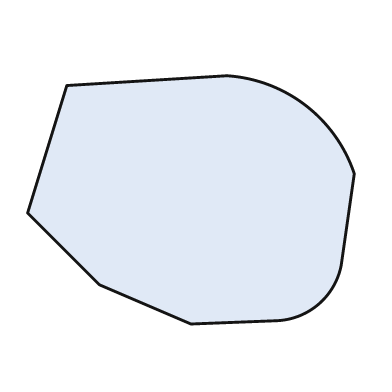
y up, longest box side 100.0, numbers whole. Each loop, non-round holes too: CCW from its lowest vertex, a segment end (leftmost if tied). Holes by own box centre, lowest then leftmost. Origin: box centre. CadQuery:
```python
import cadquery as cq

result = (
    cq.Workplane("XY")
    .moveTo(0.0, -38.0)
    .lineTo(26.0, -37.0)
    .threePointArc((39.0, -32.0), (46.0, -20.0))
    .lineTo(50.0, 8.0)
    .threePointArc((35.0, 29.0), (11.0, 38.0))
    .lineTo(-38.0, 35.0)
    .lineTo(-50.0, -4.0)
    .lineTo(-28.0, -26.0)
    .close()
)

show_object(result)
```